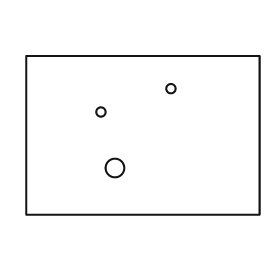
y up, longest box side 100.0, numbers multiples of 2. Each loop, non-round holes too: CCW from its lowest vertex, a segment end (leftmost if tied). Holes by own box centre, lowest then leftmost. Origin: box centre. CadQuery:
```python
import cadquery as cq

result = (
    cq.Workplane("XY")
    .moveTo(-50.0, -34.0)
    .lineTo(50.0, -34.0)
    .lineTo(50.0, 34.0)
    .lineTo(-50.0, 34.0)
    .close()
    .moveTo(-12.0, -14.0)
    .circle(4.0)
    .moveTo(-18.0, 10.0)
    .circle(2.0)
    .moveTo(12.0, 20.0)
    .circle(2.0)
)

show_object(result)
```